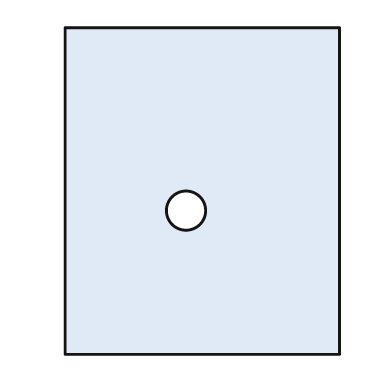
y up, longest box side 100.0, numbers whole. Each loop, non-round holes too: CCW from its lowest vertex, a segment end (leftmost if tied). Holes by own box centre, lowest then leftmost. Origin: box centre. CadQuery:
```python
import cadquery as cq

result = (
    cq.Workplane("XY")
    .moveTo(-42.0, -50.0)
    .lineTo(42.0, -50.0)
    .lineTo(42.0, 50.0)
    .lineTo(-42.0, 50.0)
    .close()
    .moveTo(-5.0, -6.0)
    .circle(6.0)
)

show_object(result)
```